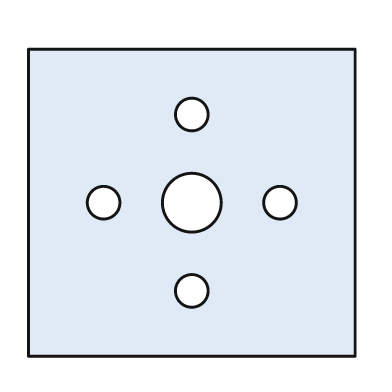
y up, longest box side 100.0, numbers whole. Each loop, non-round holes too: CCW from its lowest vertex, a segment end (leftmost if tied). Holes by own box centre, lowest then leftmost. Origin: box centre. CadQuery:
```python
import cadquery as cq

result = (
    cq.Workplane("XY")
    .moveTo(-50.0, -47.0)
    .lineTo(50.0, -47.0)
    .lineTo(50.0, 47.0)
    .lineTo(-50.0, 47.0)
    .close()
    .moveTo(0.0, -27.0)
    .circle(5.0)
    .moveTo(-27.0, 0.0)
    .circle(5.0)
    .moveTo(0.0, 0.0)
    .circle(9.0)
    .moveTo(27.0, 0.0)
    .circle(5.0)
    .moveTo(0.0, 27.0)
    .circle(5.0)
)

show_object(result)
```